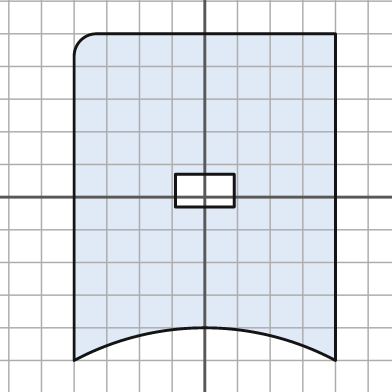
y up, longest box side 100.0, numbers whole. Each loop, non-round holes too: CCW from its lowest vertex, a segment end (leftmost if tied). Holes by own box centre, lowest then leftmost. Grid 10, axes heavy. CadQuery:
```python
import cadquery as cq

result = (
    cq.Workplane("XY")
    .moveTo(-40.0, -50.0)
    .threePointArc((0.0, -40.0), (40.0, -50.0))
    .lineTo(40.0, 50.0)
    .lineTo(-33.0, 50.0)
    .threePointArc((-38.0, 48.0), (-40.0, 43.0))
    .close()
    .moveTo(-9.0, -3.0)
    .lineTo(9.0, -3.0)
    .lineTo(9.0, 7.0)
    .lineTo(-9.0, 7.0)
    .close()
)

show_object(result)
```